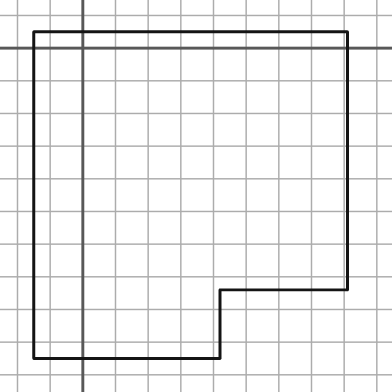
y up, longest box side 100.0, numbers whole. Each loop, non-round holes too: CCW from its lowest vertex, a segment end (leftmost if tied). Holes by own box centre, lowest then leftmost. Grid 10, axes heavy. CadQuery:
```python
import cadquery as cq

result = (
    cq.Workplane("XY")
    .moveTo(-15.0, -95.0)
    .lineTo(42.0, -95.0)
    .lineTo(42.0, -74.0)
    .lineTo(81.0, -74.0)
    .lineTo(81.0, 5.0)
    .lineTo(-15.0, 5.0)
    .close()
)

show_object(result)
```